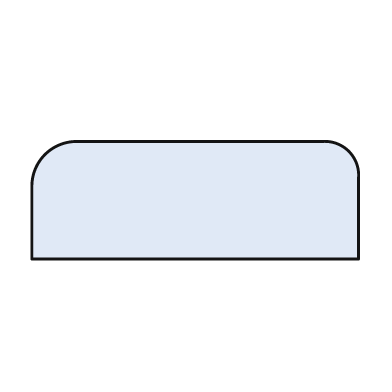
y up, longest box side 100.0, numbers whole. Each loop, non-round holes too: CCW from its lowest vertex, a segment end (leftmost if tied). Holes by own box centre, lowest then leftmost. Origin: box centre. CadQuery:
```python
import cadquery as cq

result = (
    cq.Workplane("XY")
    .moveTo(-50.0, -18.0)
    .lineTo(50.0, -18.0)
    .lineTo(50.0, 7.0)
    .threePointArc((47.0, 15.0), (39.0, 18.0))
    .lineTo(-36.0, 18.0)
    .threePointArc((-46.0, 14.0), (-50.0, 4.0))
    .close()
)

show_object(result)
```